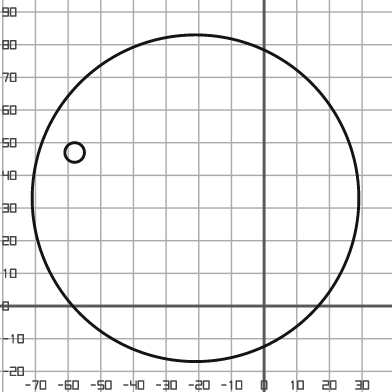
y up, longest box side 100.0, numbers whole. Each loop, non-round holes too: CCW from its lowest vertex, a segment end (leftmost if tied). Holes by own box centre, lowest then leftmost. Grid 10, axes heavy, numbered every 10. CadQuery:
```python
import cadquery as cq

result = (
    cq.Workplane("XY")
    .moveTo(-21.0, 33.0)
    .circle(50.0)
    .moveTo(-58.0, 47.0)
    .circle(3.0)
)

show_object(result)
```